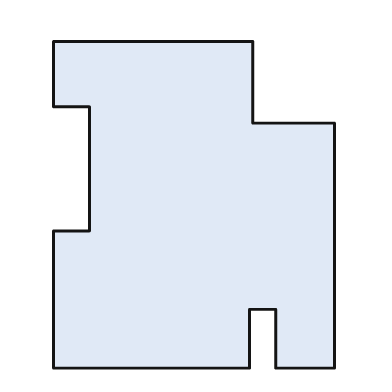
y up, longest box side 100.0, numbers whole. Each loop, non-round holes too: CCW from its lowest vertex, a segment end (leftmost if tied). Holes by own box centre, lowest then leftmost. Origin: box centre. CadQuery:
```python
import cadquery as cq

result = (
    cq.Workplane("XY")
    .moveTo(-43.0, -50.0)
    .lineTo(17.0, -50.0)
    .lineTo(17.0, -32.0)
    .lineTo(25.0, -32.0)
    .lineTo(25.0, -50.0)
    .lineTo(43.0, -50.0)
    .lineTo(43.0, 25.0)
    .lineTo(18.0, 25.0)
    .lineTo(18.0, 50.0)
    .lineTo(-43.0, 50.0)
    .lineTo(-43.0, 30.0)
    .lineTo(-32.0, 30.0)
    .lineTo(-32.0, -8.0)
    .lineTo(-43.0, -8.0)
    .close()
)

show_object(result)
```